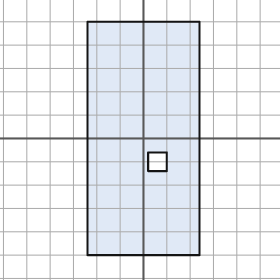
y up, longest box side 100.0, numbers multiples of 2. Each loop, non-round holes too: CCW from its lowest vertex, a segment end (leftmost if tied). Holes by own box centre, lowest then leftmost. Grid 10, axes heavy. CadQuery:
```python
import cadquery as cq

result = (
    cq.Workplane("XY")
    .moveTo(-24.0, -50.0)
    .lineTo(24.0, -50.0)
    .lineTo(24.0, 50.0)
    .lineTo(-24.0, 50.0)
    .close()
    .moveTo(2.0, -14.0)
    .lineTo(10.0, -14.0)
    .lineTo(10.0, -6.0)
    .lineTo(2.0, -6.0)
    .close()
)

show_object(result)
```